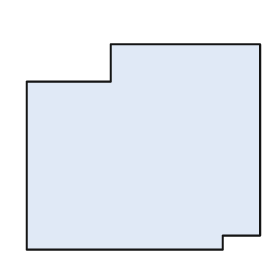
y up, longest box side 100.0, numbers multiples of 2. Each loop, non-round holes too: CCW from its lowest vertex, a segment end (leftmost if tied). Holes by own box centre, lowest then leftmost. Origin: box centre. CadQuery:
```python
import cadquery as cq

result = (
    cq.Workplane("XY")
    .moveTo(-50.0, -44.0)
    .lineTo(34.0, -44.0)
    .lineTo(34.0, -38.0)
    .lineTo(50.0, -38.0)
    .lineTo(50.0, 44.0)
    .lineTo(-14.0, 44.0)
    .lineTo(-14.0, 28.0)
    .lineTo(-50.0, 28.0)
    .close()
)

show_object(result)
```